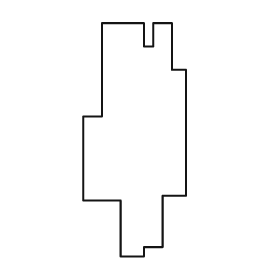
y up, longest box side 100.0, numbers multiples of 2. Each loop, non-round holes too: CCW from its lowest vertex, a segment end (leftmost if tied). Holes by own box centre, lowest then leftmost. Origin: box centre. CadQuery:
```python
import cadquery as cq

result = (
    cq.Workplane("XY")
    .moveTo(-6.0, -50.0)
    .lineTo(4.0, -50.0)
    .lineTo(4.0, -46.0)
    .lineTo(12.0, -46.0)
    .lineTo(12.0, -24.0)
    .lineTo(22.0, -24.0)
    .lineTo(22.0, 30.0)
    .lineTo(16.0, 30.0)
    .lineTo(16.0, 50.0)
    .lineTo(8.0, 50.0)
    .lineTo(8.0, 40.0)
    .lineTo(4.0, 40.0)
    .lineTo(4.0, 50.0)
    .lineTo(-14.0, 50.0)
    .lineTo(-14.0, 10.0)
    .lineTo(-22.0, 10.0)
    .lineTo(-22.0, -26.0)
    .lineTo(-6.0, -26.0)
    .close()
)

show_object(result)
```